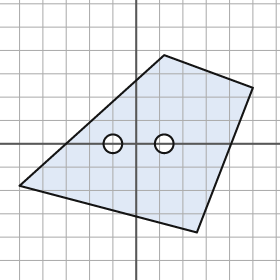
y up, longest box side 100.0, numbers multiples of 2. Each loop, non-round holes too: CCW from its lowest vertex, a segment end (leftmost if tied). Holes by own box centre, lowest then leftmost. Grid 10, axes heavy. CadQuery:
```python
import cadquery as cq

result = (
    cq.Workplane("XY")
    .moveTo(26.0, -38.0)
    .lineTo(50.0, 24.0)
    .lineTo(12.0, 38.0)
    .lineTo(-50.0, -18.0)
    .close()
    .moveTo(-10.0, 0.0)
    .circle(4.0)
    .moveTo(12.0, 0.0)
    .circle(4.0)
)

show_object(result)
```